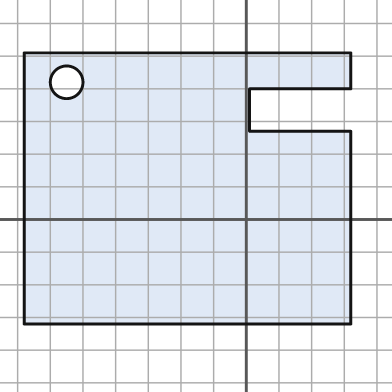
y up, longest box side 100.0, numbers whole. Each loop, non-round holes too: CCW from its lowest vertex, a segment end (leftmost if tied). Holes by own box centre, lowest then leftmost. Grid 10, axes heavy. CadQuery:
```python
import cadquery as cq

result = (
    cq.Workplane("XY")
    .moveTo(-68.0, -32.0)
    .lineTo(32.0, -32.0)
    .lineTo(32.0, 27.0)
    .lineTo(1.0, 27.0)
    .lineTo(1.0, 40.0)
    .lineTo(32.0, 40.0)
    .lineTo(32.0, 51.0)
    .lineTo(-68.0, 51.0)
    .close()
    .moveTo(-55.0, 42.0)
    .circle(5.0)
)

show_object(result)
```